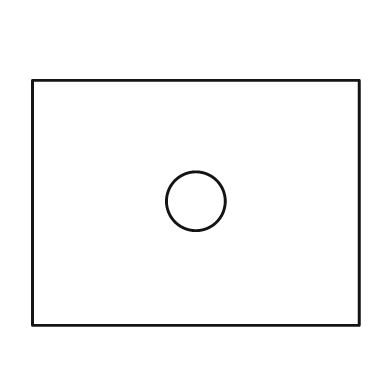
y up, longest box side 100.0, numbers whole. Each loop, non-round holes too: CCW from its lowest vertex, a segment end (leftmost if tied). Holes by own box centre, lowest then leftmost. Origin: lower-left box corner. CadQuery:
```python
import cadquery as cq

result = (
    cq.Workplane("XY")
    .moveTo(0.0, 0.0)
    .lineTo(100.0, 0.0)
    .lineTo(100.0, 75.0)
    .lineTo(0.0, 75.0)
    .close()
    .moveTo(50.0, 38.0)
    .circle(9.0)
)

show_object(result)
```